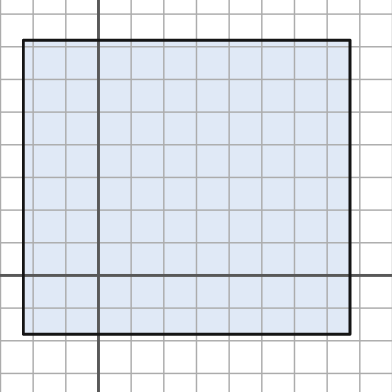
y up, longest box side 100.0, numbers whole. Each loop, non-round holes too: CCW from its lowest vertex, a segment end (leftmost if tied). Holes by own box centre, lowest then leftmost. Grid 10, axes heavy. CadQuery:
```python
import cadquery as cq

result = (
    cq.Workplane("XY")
    .moveTo(-23.0, -18.0)
    .lineTo(77.0, -18.0)
    .lineTo(77.0, 72.0)
    .lineTo(-23.0, 72.0)
    .close()
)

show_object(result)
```